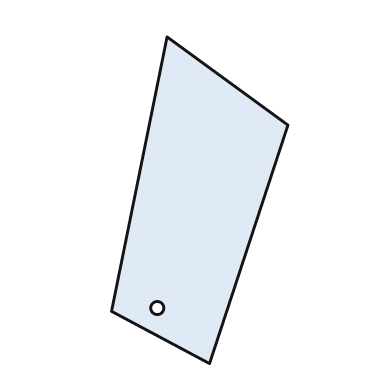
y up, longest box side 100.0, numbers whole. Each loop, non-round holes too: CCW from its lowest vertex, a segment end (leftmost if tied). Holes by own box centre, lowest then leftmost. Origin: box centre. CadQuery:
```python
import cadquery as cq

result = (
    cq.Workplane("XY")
    .moveTo(3.0, -50.0)
    .lineTo(27.0, 23.0)
    .lineTo(-10.0, 50.0)
    .lineTo(-27.0, -34.0)
    .close()
    .moveTo(-13.0, -33.0)
    .circle(2.0)
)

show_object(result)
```